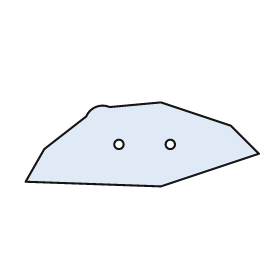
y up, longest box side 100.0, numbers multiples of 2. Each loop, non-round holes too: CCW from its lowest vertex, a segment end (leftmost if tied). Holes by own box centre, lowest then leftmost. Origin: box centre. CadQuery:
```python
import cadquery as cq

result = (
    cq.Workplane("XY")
    .moveTo(8.0, -18.0)
    .lineTo(50.0, -4.0)
    .lineTo(38.0, 8.0)
    .lineTo(8.0, 18.0)
    .lineTo(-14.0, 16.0)
    .threePointArc((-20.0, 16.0), (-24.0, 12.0))
    .lineTo(-42.0, -2.0)
    .lineTo(-50.0, -16.0)
    .close()
    .moveTo(-10.0, 0.0)
    .circle(2.0)
    .moveTo(12.0, 0.0)
    .circle(2.0)
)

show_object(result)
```